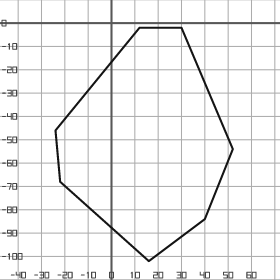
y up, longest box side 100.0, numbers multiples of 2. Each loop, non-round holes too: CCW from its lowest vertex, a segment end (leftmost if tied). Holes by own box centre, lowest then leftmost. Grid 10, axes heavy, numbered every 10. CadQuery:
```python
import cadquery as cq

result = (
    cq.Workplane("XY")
    .moveTo(16.0, -102.0)
    .lineTo(40.0, -84.0)
    .lineTo(52.0, -54.0)
    .lineTo(30.0, -2.0)
    .lineTo(12.0, -2.0)
    .lineTo(-24.0, -46.0)
    .lineTo(-22.0, -68.0)
    .close()
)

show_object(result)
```